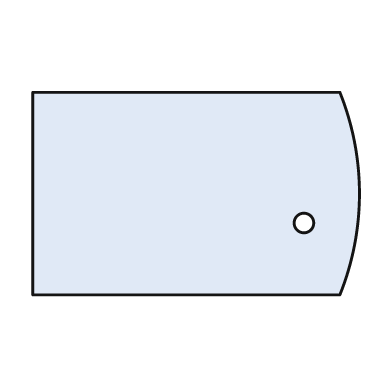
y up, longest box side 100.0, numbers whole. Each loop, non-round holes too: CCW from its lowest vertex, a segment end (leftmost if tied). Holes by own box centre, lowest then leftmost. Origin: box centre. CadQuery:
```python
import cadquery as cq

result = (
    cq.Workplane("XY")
    .moveTo(-50.0, -31.0)
    .lineTo(44.0, -31.0)
    .threePointArc((50.0, 0.0), (44.0, 31.0))
    .lineTo(-50.0, 31.0)
    .close()
    .moveTo(33.0, -9.0)
    .circle(3.0)
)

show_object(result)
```